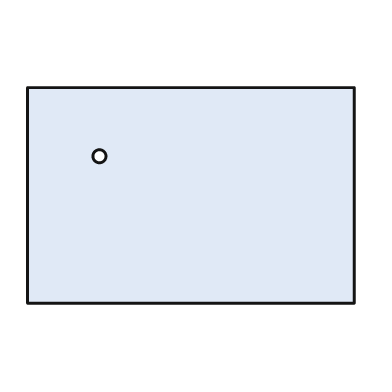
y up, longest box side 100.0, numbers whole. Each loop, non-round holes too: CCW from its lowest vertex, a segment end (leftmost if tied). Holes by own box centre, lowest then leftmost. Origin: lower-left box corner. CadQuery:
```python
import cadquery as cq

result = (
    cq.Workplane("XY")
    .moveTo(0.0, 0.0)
    .lineTo(100.0, 0.0)
    .lineTo(100.0, 66.0)
    .lineTo(0.0, 66.0)
    .close()
    .moveTo(22.0, 45.0)
    .circle(2.0)
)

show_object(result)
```